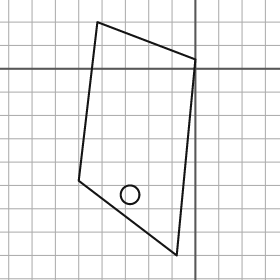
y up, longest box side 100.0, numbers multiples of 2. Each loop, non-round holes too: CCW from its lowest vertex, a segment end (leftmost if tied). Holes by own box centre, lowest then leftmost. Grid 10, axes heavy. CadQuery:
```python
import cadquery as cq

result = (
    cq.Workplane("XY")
    .moveTo(-8.0, -80.0)
    .lineTo(0.0, 4.0)
    .lineTo(-42.0, 20.0)
    .lineTo(-50.0, -48.0)
    .close()
    .moveTo(-28.0, -54.0)
    .circle(4.0)
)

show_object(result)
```